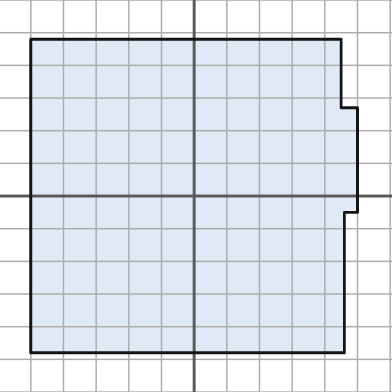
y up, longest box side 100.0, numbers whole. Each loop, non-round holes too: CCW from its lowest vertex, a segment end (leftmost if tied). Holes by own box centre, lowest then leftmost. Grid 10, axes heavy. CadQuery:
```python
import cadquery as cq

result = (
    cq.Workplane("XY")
    .moveTo(-50.0, -48.0)
    .lineTo(46.0, -48.0)
    .lineTo(46.0, -5.0)
    .lineTo(50.0, -5.0)
    .lineTo(50.0, 27.0)
    .lineTo(45.0, 27.0)
    .lineTo(45.0, 48.0)
    .lineTo(-50.0, 48.0)
    .close()
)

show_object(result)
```